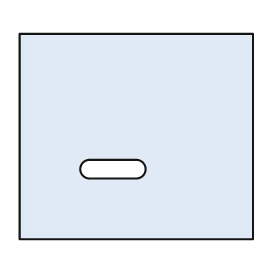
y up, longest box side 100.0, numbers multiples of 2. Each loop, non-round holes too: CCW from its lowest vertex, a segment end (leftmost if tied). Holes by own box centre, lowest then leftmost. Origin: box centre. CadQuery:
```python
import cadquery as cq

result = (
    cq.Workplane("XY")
    .moveTo(-50.0, -44.0)
    .lineTo(50.0, -44.0)
    .lineTo(50.0, 44.0)
    .lineTo(-50.0, 44.0)
    .close()
    .moveTo(-20.0, -18.0)
    .lineTo(0.0, -18.0)
    .threePointArc((4.0, -14.0), (0.0, -10.0))
    .lineTo(-20.0, -10.0)
    .threePointArc((-24.0, -14.0), (-20.0, -18.0))
    .close()
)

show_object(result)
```